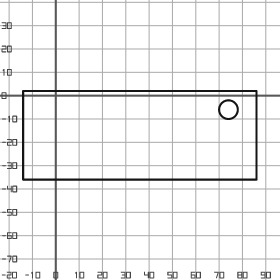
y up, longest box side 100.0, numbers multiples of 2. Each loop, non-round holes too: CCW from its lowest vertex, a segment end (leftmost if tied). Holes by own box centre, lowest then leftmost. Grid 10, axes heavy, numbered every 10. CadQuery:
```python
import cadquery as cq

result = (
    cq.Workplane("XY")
    .moveTo(-14.0, -36.0)
    .lineTo(86.0, -36.0)
    .lineTo(86.0, 2.0)
    .lineTo(-14.0, 2.0)
    .close()
    .moveTo(74.0, -6.0)
    .circle(4.0)
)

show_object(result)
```